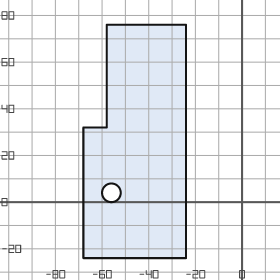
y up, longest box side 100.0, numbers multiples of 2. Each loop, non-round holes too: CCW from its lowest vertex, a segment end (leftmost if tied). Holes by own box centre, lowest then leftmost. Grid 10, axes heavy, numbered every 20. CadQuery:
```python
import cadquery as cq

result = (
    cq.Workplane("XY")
    .moveTo(-68.0, -24.0)
    .lineTo(-24.0, -24.0)
    .lineTo(-24.0, 76.0)
    .lineTo(-58.0, 76.0)
    .lineTo(-58.0, 32.0)
    .lineTo(-68.0, 32.0)
    .close()
    .moveTo(-56.0, 4.0)
    .circle(4.0)
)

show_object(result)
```